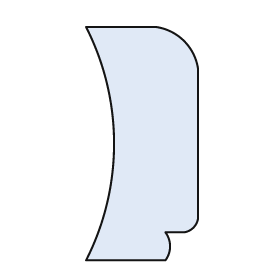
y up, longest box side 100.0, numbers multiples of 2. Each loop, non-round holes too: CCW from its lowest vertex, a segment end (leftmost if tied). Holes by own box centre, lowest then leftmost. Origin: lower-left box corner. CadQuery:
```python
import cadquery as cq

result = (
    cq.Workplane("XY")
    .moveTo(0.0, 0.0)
    .lineTo(34.0, 0.0)
    .threePointArc((36.0, 6.0), (34.0, 12.0))
    .lineTo(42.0, 12.0)
    .threePointArc((46.0, 14.0), (48.0, 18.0))
    .lineTo(48.0, 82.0)
    .threePointArc((42.0, 94.0), (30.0, 100.0))
    .lineTo(0.0, 100.0)
    .threePointArc((12.0, 50.0), (0.0, 0.0))
    .close()
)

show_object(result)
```